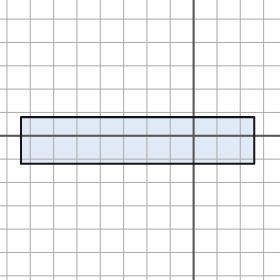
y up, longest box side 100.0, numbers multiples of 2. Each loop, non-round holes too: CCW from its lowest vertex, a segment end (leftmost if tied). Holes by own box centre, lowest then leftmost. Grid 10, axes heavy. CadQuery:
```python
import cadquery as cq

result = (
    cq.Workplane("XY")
    .moveTo(-74.0, -12.0)
    .lineTo(26.0, -12.0)
    .lineTo(26.0, 8.0)
    .lineTo(-74.0, 8.0)
    .close()
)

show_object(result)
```